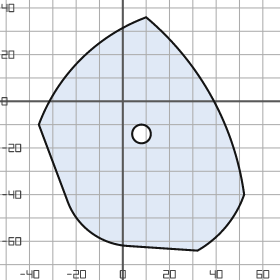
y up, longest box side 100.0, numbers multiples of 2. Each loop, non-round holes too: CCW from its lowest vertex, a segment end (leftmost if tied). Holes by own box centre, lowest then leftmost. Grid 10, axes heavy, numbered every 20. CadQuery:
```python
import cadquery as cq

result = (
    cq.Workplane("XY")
    .moveTo(32.0, -64.0)
    .threePointArc((44.0, -54.0), (52.0, -40.0))
    .threePointArc((38.0, 2.0), (10.0, 36.0))
    .threePointArc((-18.0, 18.0), (-36.0, -10.0))
    .lineTo(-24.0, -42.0)
    .threePointArc((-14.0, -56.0), (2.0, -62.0))
    .close()
    .moveTo(8.0, -14.0)
    .circle(4.0)
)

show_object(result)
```